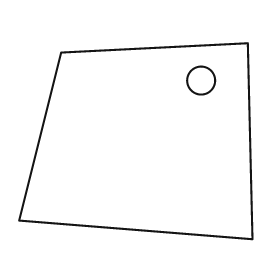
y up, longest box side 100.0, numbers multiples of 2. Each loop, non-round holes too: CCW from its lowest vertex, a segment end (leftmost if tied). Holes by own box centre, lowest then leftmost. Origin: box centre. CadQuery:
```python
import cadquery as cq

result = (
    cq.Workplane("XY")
    .moveTo(50.0, -42.0)
    .lineTo(48.0, 42.0)
    .lineTo(-32.0, 38.0)
    .lineTo(-50.0, -34.0)
    .close()
    .moveTo(28.0, 26.0)
    .circle(6.0)
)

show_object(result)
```